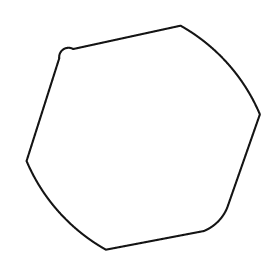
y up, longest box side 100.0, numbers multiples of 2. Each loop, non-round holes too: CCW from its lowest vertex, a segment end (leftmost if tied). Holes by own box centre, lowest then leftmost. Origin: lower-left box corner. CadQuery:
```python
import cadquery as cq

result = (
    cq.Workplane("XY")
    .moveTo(34.0, 0.0)
    .lineTo(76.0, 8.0)
    .threePointArc((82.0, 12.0), (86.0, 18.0))
    .lineTo(100.0, 58.0)
    .threePointArc((86.0, 80.0), (66.0, 96.0))
    .lineTo(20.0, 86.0)
    .threePointArc((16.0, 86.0), (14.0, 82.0))
    .lineTo(0.0, 38.0)
    .threePointArc((14.0, 16.0), (34.0, 0.0))
    .close()
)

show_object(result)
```